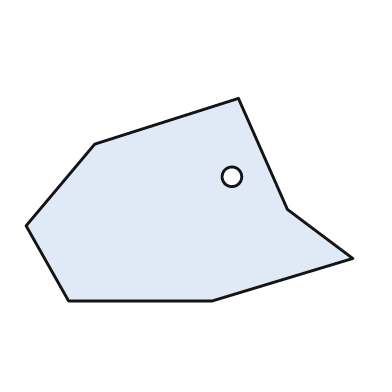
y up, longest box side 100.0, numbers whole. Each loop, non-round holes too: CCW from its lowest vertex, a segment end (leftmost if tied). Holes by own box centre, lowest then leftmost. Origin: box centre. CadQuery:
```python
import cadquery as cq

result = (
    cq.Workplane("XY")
    .moveTo(-37.0, -31.0)
    .lineTo(7.0, -31.0)
    .lineTo(50.0, -18.0)
    .lineTo(30.0, -3.0)
    .lineTo(15.0, 31.0)
    .lineTo(-29.0, 17.0)
    .lineTo(-50.0, -8.0)
    .close()
    .moveTo(13.0, 7.0)
    .circle(3.0)
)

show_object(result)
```